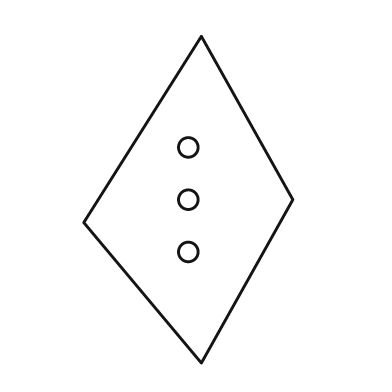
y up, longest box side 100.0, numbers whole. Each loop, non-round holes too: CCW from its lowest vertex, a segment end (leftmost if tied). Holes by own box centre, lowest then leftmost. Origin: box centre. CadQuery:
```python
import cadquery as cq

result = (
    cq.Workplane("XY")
    .moveTo(4.0, -50.0)
    .lineTo(32.0, 0.0)
    .lineTo(4.0, 50.0)
    .lineTo(-32.0, -7.0)
    .close()
    .moveTo(0.0, -16.0)
    .circle(3.0)
    .moveTo(0.0, 0.0)
    .circle(3.0)
    .moveTo(0.0, 16.0)
    .circle(3.0)
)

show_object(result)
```